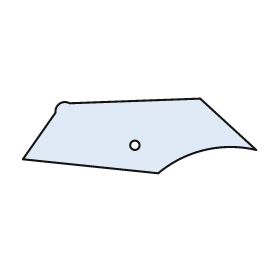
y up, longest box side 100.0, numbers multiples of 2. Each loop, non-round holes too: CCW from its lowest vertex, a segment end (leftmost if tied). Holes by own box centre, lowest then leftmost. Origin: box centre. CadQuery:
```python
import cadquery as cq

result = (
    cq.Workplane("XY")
    .moveTo(8.0, -16.0)
    .threePointArc((28.0, -6.0), (50.0, -6.0))
    .lineTo(26.0, 16.0)
    .lineTo(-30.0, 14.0)
    .threePointArc((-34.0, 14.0), (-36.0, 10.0))
    .lineTo(-50.0, -10.0)
    .close()
    .moveTo(-2.0, -4.0)
    .circle(2.0)
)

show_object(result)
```